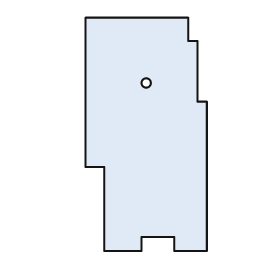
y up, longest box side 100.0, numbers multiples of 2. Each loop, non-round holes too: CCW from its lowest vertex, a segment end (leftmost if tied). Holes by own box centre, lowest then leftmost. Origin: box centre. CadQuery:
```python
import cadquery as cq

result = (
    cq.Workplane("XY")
    .moveTo(-18.0, -50.0)
    .lineTo(-2.0, -50.0)
    .lineTo(-2.0, -44.0)
    .lineTo(12.0, -44.0)
    .lineTo(12.0, -50.0)
    .lineTo(26.0, -50.0)
    .lineTo(26.0, 14.0)
    .lineTo(22.0, 14.0)
    .lineTo(22.0, 40.0)
    .lineTo(18.0, 40.0)
    .lineTo(18.0, 50.0)
    .lineTo(-26.0, 50.0)
    .lineTo(-26.0, -14.0)
    .lineTo(-18.0, -14.0)
    .close()
    .moveTo(0.0, 22.0)
    .circle(2.0)
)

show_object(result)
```